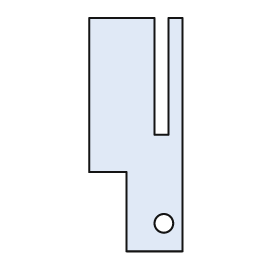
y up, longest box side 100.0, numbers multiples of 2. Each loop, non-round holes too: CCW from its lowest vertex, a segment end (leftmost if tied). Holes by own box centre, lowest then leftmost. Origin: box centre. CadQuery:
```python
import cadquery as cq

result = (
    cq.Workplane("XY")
    .moveTo(-4.0, -50.0)
    .lineTo(20.0, -50.0)
    .lineTo(20.0, 50.0)
    .lineTo(14.0, 50.0)
    .lineTo(14.0, 0.0)
    .lineTo(8.0, 0.0)
    .lineTo(8.0, 50.0)
    .lineTo(-20.0, 50.0)
    .lineTo(-20.0, -16.0)
    .lineTo(-4.0, -16.0)
    .close()
    .moveTo(12.0, -38.0)
    .circle(4.0)
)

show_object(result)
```